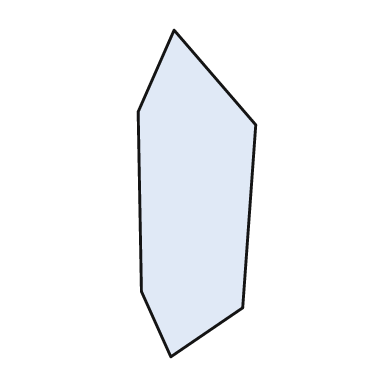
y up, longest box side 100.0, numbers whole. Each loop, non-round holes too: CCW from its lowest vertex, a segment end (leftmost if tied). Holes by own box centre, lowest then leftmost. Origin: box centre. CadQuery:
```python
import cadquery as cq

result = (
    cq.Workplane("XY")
    .moveTo(-8.0, -50.0)
    .lineTo(14.0, -35.0)
    .lineTo(18.0, 21.0)
    .lineTo(-7.0, 50.0)
    .lineTo(-18.0, 25.0)
    .lineTo(-17.0, -30.0)
    .close()
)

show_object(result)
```